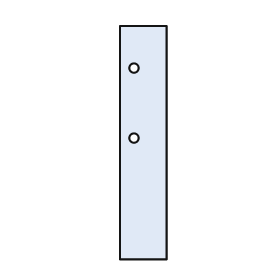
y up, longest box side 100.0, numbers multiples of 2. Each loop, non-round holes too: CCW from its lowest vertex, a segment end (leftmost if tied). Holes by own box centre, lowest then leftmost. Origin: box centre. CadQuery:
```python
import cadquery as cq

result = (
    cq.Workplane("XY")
    .moveTo(-10.0, -50.0)
    .lineTo(10.0, -50.0)
    .lineTo(10.0, 50.0)
    .lineTo(-10.0, 50.0)
    .close()
    .moveTo(-4.0, 2.0)
    .circle(2.0)
    .moveTo(-4.0, 32.0)
    .circle(2.0)
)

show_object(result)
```